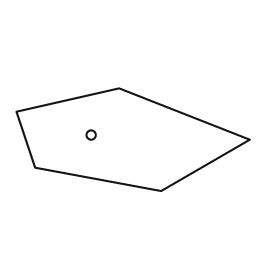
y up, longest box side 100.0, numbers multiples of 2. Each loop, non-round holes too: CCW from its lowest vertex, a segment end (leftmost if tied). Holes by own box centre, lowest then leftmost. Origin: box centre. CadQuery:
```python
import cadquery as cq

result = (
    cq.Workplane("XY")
    .moveTo(12.0, -22.0)
    .lineTo(50.0, 0.0)
    .lineTo(-6.0, 22.0)
    .lineTo(-50.0, 12.0)
    .lineTo(-42.0, -12.0)
    .close()
    .moveTo(-18.0, 2.0)
    .circle(2.0)
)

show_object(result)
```